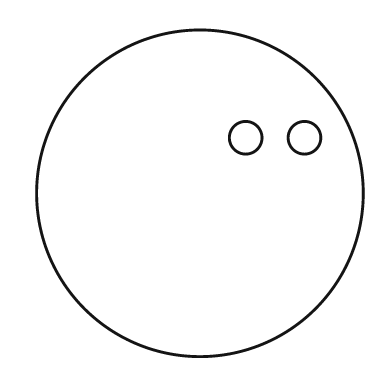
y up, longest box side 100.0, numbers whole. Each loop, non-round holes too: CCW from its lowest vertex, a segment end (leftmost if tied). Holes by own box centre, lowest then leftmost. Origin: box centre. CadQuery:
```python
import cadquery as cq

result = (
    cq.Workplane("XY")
    .moveTo(0.0, 0.0)
    .circle(50.0)
    .moveTo(14.0, 17.0)
    .circle(5.0)
    .moveTo(32.0, 17.0)
    .circle(5.0)
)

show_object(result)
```